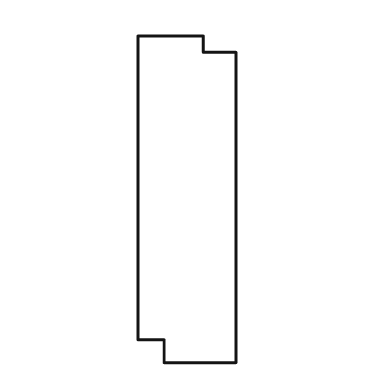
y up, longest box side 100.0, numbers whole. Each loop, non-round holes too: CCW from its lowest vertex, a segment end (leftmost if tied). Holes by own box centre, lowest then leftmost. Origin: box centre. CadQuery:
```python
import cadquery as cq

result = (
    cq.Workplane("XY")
    .moveTo(-7.0, -50.0)
    .lineTo(15.0, -50.0)
    .lineTo(15.0, 45.0)
    .lineTo(5.0, 45.0)
    .lineTo(5.0, 50.0)
    .lineTo(-15.0, 50.0)
    .lineTo(-15.0, -43.0)
    .lineTo(-7.0, -43.0)
    .close()
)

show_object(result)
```